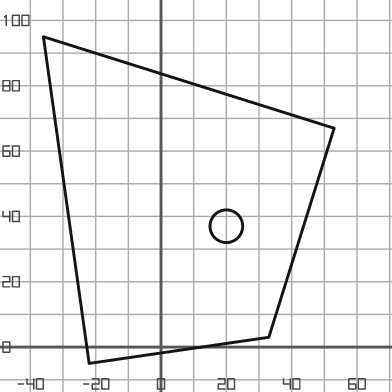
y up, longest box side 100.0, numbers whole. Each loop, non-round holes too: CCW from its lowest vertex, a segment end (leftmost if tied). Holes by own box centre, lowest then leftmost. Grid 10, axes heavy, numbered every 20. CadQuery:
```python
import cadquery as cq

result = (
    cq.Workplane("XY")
    .moveTo(-22.0, -5.0)
    .lineTo(33.0, 3.0)
    .lineTo(53.0, 67.0)
    .lineTo(-36.0, 95.0)
    .close()
    .moveTo(20.0, 37.0)
    .circle(5.0)
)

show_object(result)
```